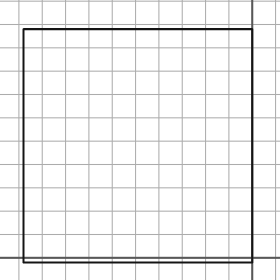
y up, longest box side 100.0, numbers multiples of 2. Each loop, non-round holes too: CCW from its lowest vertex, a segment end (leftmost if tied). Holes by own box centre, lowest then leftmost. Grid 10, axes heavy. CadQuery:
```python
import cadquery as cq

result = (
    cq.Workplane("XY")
    .moveTo(-98.0, -2.0)
    .lineTo(0.0, -2.0)
    .lineTo(0.0, 98.0)
    .lineTo(-98.0, 98.0)
    .close()
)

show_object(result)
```